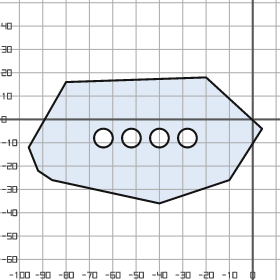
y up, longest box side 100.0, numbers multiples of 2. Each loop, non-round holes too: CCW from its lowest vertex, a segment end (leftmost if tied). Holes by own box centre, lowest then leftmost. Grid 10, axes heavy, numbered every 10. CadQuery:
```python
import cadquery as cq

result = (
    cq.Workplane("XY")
    .moveTo(-40.0, -36.0)
    .lineTo(-10.0, -26.0)
    .lineTo(4.0, -4.0)
    .lineTo(-20.0, 18.0)
    .lineTo(-80.0, 16.0)
    .lineTo(-96.0, -12.0)
    .lineTo(-92.0, -22.0)
    .lineTo(-86.0, -26.0)
    .close()
    .moveTo(-64.0, -8.0)
    .circle(4.0)
    .moveTo(-52.0, -8.0)
    .circle(4.0)
    .moveTo(-40.0, -8.0)
    .circle(4.0)
    .moveTo(-28.0, -8.0)
    .circle(4.0)
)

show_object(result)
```